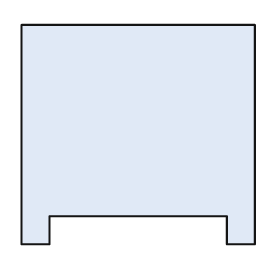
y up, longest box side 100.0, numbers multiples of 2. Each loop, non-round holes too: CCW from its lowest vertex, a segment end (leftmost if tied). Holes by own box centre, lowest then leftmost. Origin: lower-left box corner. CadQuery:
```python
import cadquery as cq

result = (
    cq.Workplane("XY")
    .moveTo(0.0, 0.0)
    .lineTo(12.0, 0.0)
    .lineTo(12.0, 12.0)
    .lineTo(88.0, 12.0)
    .lineTo(88.0, 0.0)
    .lineTo(100.0, 0.0)
    .lineTo(100.0, 94.0)
    .lineTo(0.0, 94.0)
    .close()
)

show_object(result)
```